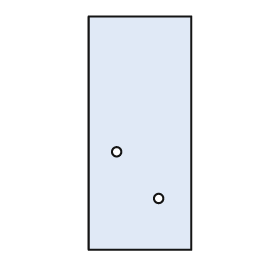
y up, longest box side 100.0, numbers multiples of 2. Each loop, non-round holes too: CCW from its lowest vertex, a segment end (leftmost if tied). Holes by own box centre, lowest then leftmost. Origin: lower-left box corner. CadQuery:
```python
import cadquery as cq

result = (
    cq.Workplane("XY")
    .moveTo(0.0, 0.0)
    .lineTo(44.0, 0.0)
    .lineTo(44.0, 100.0)
    .lineTo(0.0, 100.0)
    .close()
    .moveTo(30.0, 22.0)
    .circle(2.0)
    .moveTo(12.0, 42.0)
    .circle(2.0)
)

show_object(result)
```